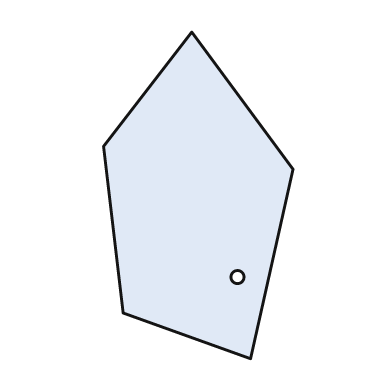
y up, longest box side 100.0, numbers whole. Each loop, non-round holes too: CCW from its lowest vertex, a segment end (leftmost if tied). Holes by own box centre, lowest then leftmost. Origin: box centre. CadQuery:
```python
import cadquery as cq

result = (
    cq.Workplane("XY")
    .moveTo(16.0, -50.0)
    .lineTo(29.0, 8.0)
    .lineTo(-2.0, 50.0)
    .lineTo(-29.0, 15.0)
    .lineTo(-23.0, -36.0)
    .close()
    .moveTo(12.0, -25.0)
    .circle(2.0)
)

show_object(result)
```